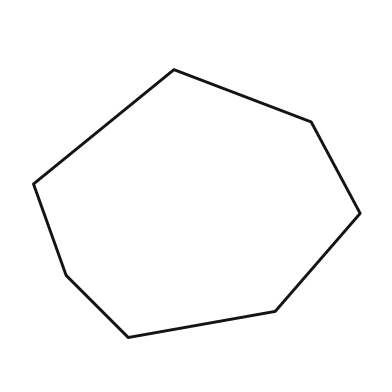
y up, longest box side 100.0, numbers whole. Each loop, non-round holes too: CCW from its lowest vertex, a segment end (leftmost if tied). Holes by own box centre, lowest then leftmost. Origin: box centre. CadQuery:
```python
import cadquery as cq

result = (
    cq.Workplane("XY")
    .moveTo(-21.0, -41.0)
    .lineTo(24.0, -33.0)
    .lineTo(50.0, -3.0)
    .lineTo(35.0, 25.0)
    .lineTo(-7.0, 41.0)
    .lineTo(-50.0, 6.0)
    .lineTo(-40.0, -22.0)
    .close()
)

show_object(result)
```